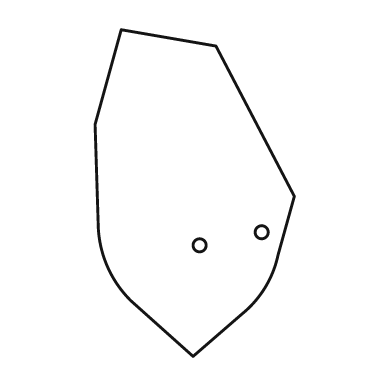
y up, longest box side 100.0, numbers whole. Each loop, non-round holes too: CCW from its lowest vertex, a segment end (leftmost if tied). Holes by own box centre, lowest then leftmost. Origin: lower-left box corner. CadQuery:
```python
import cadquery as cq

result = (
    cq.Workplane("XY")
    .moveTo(30.0, 0.0)
    .lineTo(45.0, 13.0)
    .threePointArc((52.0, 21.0), (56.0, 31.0))
    .lineTo(61.0, 49.0)
    .lineTo(37.0, 95.0)
    .lineTo(8.0, 100.0)
    .lineTo(0.0, 71.0)
    .lineTo(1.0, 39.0)
    .threePointArc((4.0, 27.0), (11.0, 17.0))
    .close()
    .moveTo(32.0, 34.0)
    .circle(2.0)
    .moveTo(51.0, 38.0)
    .circle(2.0)
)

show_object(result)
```